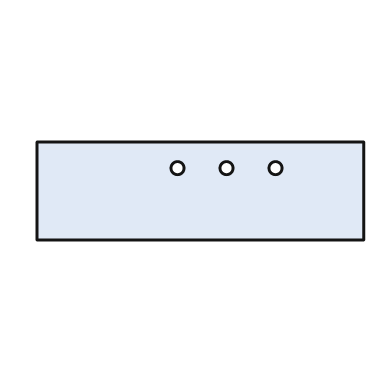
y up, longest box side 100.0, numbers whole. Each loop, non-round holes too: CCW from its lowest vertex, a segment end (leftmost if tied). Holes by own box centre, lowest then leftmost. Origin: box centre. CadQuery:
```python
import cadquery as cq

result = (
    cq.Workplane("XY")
    .moveTo(-50.0, -15.0)
    .lineTo(50.0, -15.0)
    .lineTo(50.0, 15.0)
    .lineTo(-50.0, 15.0)
    .close()
    .moveTo(-7.0, 7.0)
    .circle(2.0)
    .moveTo(8.0, 7.0)
    .circle(2.0)
    .moveTo(23.0, 7.0)
    .circle(2.0)
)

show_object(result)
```